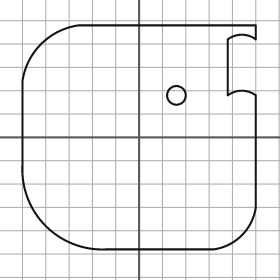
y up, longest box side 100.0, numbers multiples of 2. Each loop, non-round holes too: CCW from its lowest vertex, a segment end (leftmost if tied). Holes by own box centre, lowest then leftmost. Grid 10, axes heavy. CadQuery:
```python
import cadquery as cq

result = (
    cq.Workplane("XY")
    .moveTo(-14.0, -48.0)
    .lineTo(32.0, -48.0)
    .threePointArc((44.0, -42.0), (50.0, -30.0))
    .lineTo(50.0, 18.0)
    .threePointArc((44.0, 20.0), (38.0, 18.0))
    .lineTo(38.0, 42.0)
    .threePointArc((44.0, 44.0), (50.0, 42.0))
    .lineTo(50.0, 48.0)
    .lineTo(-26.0, 48.0)
    .threePointArc((-42.0, 40.0), (-50.0, 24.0))
    .lineTo(-50.0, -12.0)
    .threePointArc((-40.0, -38.0), (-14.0, -48.0))
    .close()
    .moveTo(16.0, 18.0)
    .circle(4.0)
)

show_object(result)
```